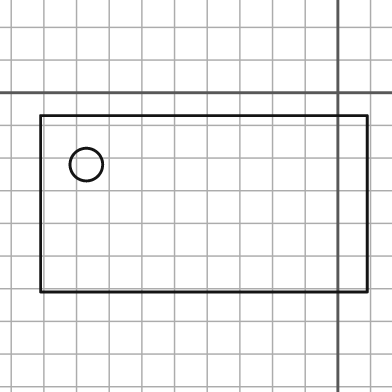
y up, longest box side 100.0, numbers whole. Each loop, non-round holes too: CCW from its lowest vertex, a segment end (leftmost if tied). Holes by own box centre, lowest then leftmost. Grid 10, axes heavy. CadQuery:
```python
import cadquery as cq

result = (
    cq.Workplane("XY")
    .moveTo(-91.0, -61.0)
    .lineTo(9.0, -61.0)
    .lineTo(9.0, -7.0)
    .lineTo(-91.0, -7.0)
    .close()
    .moveTo(-77.0, -22.0)
    .circle(5.0)
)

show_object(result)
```